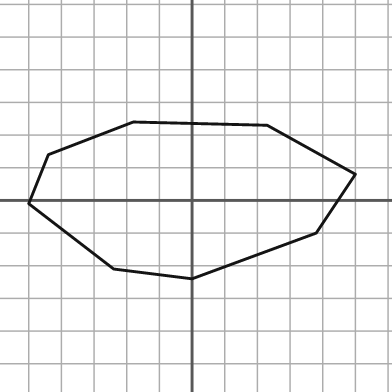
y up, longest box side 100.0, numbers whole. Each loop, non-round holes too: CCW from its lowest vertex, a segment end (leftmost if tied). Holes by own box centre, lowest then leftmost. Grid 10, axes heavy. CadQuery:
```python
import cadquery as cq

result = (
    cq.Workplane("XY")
    .moveTo(0.0, -24.0)
    .lineTo(38.0, -10.0)
    .lineTo(50.0, 8.0)
    .lineTo(23.0, 23.0)
    .lineTo(-18.0, 24.0)
    .lineTo(-44.0, 14.0)
    .lineTo(-50.0, -1.0)
    .lineTo(-24.0, -21.0)
    .close()
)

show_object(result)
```